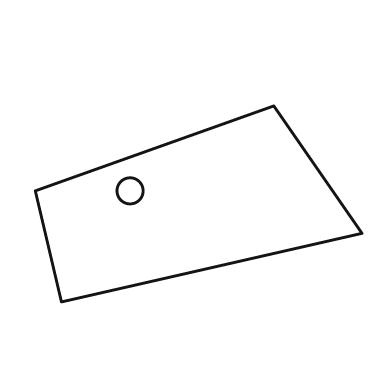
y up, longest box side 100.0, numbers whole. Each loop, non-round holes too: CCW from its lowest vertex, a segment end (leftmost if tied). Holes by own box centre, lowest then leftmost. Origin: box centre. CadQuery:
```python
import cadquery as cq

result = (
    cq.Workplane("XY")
    .moveTo(-42.0, -30.0)
    .lineTo(50.0, -9.0)
    .lineTo(23.0, 30.0)
    .lineTo(-50.0, 4.0)
    .close()
    .moveTo(-21.0, 4.0)
    .circle(4.0)
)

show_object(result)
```